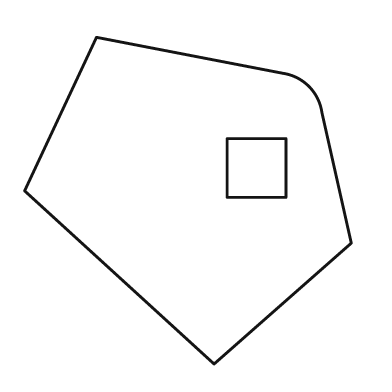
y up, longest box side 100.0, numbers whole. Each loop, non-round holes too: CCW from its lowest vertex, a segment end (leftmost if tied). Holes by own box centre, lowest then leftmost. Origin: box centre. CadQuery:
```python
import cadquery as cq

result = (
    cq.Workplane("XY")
    .moveTo(8.0, -50.0)
    .lineTo(50.0, -13.0)
    .lineTo(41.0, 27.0)
    .threePointArc((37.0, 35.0), (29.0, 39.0))
    .lineTo(-28.0, 50.0)
    .lineTo(-50.0, 3.0)
    .close()
    .moveTo(12.0, 1.0)
    .lineTo(30.0, 1.0)
    .lineTo(30.0, 19.0)
    .lineTo(12.0, 19.0)
    .close()
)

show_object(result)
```